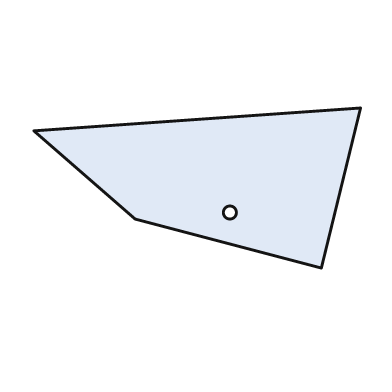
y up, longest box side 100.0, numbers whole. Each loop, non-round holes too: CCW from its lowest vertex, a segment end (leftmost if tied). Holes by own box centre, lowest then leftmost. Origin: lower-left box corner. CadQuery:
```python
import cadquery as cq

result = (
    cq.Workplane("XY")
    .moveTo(88.0, 0.0)
    .lineTo(100.0, 49.0)
    .lineTo(0.0, 42.0)
    .lineTo(31.0, 15.0)
    .close()
    .moveTo(60.0, 17.0)
    .circle(2.0)
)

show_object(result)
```